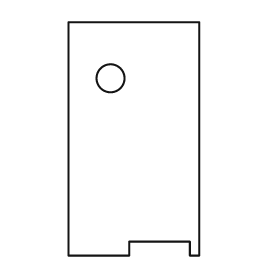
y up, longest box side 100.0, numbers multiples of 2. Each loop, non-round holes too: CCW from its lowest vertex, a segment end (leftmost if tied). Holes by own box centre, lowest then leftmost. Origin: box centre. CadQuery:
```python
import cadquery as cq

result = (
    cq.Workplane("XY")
    .moveTo(-28.0, -50.0)
    .lineTo(-2.0, -50.0)
    .lineTo(-2.0, -44.0)
    .lineTo(24.0, -44.0)
    .lineTo(24.0, -50.0)
    .lineTo(28.0, -50.0)
    .lineTo(28.0, 50.0)
    .lineTo(-28.0, 50.0)
    .close()
    .moveTo(-10.0, 26.0)
    .circle(6.0)
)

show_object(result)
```